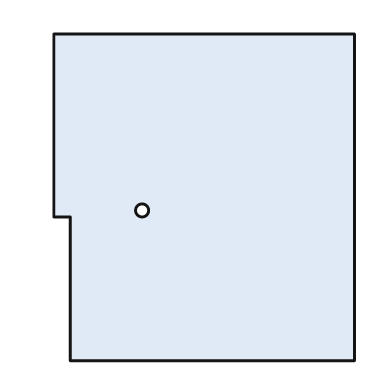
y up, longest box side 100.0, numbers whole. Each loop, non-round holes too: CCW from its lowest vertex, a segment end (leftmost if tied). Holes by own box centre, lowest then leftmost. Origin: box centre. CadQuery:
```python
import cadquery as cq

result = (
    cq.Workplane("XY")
    .moveTo(-41.0, -50.0)
    .lineTo(46.0, -50.0)
    .lineTo(46.0, 50.0)
    .lineTo(-46.0, 50.0)
    .lineTo(-46.0, -6.0)
    .lineTo(-41.0, -6.0)
    .close()
    .moveTo(-19.0, -4.0)
    .circle(2.0)
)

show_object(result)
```